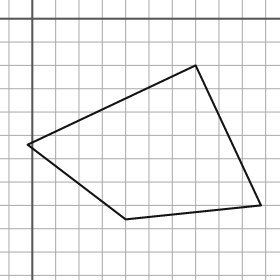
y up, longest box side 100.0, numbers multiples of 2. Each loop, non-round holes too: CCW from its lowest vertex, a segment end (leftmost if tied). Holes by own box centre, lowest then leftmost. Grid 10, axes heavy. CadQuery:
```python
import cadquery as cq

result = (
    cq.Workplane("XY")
    .moveTo(40.0, -86.0)
    .lineTo(98.0, -80.0)
    .lineTo(70.0, -20.0)
    .lineTo(-2.0, -54.0)
    .close()
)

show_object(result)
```